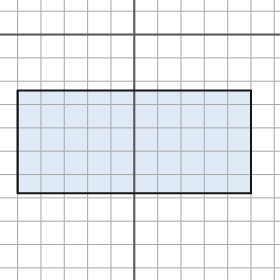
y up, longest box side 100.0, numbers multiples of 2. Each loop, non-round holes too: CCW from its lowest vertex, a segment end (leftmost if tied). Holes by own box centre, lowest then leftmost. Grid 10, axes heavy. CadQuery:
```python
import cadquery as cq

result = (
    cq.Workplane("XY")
    .moveTo(-50.0, -68.0)
    .lineTo(50.0, -68.0)
    .lineTo(50.0, -24.0)
    .lineTo(-50.0, -24.0)
    .close()
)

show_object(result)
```